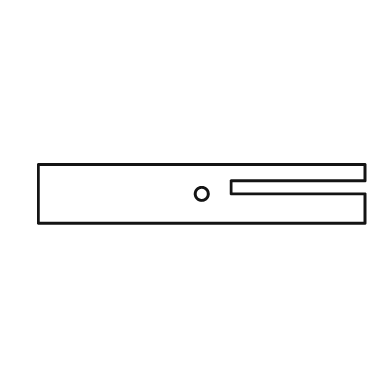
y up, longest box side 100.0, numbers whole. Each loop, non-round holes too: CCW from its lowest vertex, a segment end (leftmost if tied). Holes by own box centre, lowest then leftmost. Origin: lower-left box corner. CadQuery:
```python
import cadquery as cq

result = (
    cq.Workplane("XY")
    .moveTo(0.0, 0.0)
    .lineTo(100.0, 0.0)
    .lineTo(100.0, 9.0)
    .lineTo(59.0, 9.0)
    .lineTo(59.0, 13.0)
    .lineTo(100.0, 13.0)
    .lineTo(100.0, 18.0)
    .lineTo(0.0, 18.0)
    .close()
    .moveTo(50.0, 9.0)
    .circle(2.0)
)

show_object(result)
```